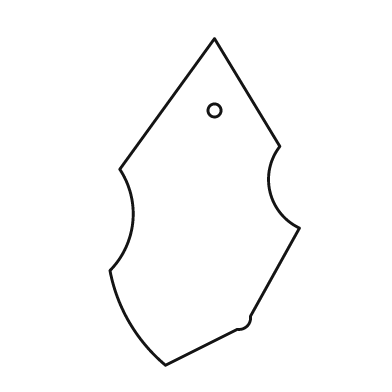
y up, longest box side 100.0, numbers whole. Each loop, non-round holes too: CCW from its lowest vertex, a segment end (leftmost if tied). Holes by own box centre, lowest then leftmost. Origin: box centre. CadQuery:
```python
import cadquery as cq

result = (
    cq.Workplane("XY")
    .moveTo(-12.0, -50.0)
    .lineTo(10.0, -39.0)
    .threePointArc((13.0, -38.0), (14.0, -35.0))
    .lineTo(29.0, -8.0)
    .threePointArc((20.0, 3.0), (23.0, 17.0))
    .lineTo(3.0, 50.0)
    .lineTo(-26.0, 10.0)
    .threePointArc((-22.0, -6.0), (-29.0, -21.0))
    .threePointArc((-23.0, -37.0), (-12.0, -50.0))
    .close()
    .moveTo(3.0, 28.0)
    .circle(2.0)
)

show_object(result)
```